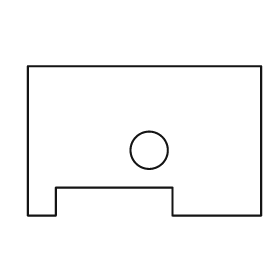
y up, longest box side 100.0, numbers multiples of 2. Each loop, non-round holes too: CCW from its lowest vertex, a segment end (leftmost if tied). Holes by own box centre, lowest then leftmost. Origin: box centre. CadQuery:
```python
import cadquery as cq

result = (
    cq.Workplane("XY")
    .moveTo(-50.0, -32.0)
    .lineTo(-38.0, -32.0)
    .lineTo(-38.0, -20.0)
    .lineTo(12.0, -20.0)
    .lineTo(12.0, -32.0)
    .lineTo(50.0, -32.0)
    .lineTo(50.0, 32.0)
    .lineTo(-50.0, 32.0)
    .close()
    .moveTo(2.0, -4.0)
    .circle(8.0)
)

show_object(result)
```